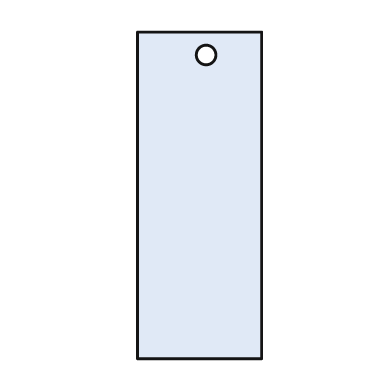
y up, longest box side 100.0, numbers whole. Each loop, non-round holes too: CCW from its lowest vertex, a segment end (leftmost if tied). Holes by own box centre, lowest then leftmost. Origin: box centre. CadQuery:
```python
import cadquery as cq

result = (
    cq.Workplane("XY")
    .moveTo(-19.0, -50.0)
    .lineTo(19.0, -50.0)
    .lineTo(19.0, 50.0)
    .lineTo(-19.0, 50.0)
    .close()
    .moveTo(2.0, 43.0)
    .circle(3.0)
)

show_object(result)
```